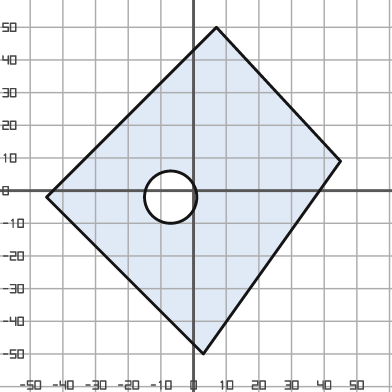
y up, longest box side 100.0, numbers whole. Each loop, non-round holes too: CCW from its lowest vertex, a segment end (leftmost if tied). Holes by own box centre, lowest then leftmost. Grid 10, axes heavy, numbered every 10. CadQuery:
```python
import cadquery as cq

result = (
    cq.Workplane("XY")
    .moveTo(3.0, -50.0)
    .lineTo(45.0, 9.0)
    .lineTo(7.0, 50.0)
    .lineTo(-45.0, -2.0)
    .close()
    .moveTo(-7.0, -2.0)
    .circle(8.0)
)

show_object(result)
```